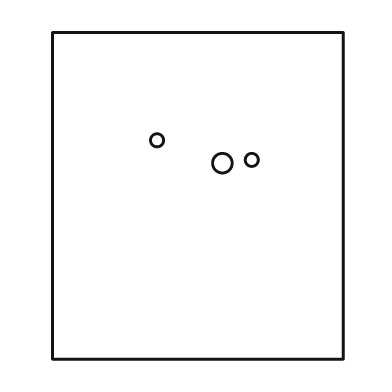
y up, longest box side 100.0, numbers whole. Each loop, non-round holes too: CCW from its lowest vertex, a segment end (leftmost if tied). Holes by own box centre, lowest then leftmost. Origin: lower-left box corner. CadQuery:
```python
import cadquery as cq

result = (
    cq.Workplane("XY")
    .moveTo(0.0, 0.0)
    .lineTo(89.0, 0.0)
    .lineTo(89.0, 100.0)
    .lineTo(0.0, 100.0)
    .close()
    .moveTo(52.0, 60.0)
    .circle(3.0)
    .moveTo(61.0, 61.0)
    .circle(2.0)
    .moveTo(32.0, 67.0)
    .circle(2.0)
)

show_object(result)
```